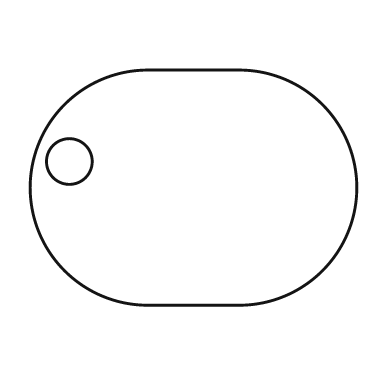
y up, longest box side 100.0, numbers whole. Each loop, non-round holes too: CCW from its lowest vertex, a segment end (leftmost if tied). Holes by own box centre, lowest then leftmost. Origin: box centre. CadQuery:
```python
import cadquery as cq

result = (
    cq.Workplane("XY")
    .moveTo(-14.0, -36.0)
    .lineTo(14.0, -36.0)
    .threePointArc((50.0, 0.0), (14.0, 36.0))
    .lineTo(-14.0, 36.0)
    .threePointArc((-50.0, 0.0), (-14.0, -36.0))
    .close()
    .moveTo(-38.0, 8.0)
    .circle(7.0)
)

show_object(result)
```